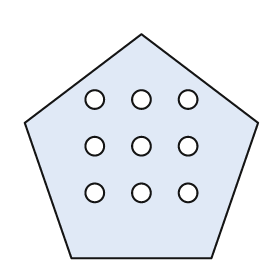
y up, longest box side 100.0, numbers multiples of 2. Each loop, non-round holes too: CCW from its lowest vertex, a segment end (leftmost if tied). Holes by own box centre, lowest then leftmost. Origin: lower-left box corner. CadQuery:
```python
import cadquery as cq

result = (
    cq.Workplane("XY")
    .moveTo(20.0, 0.0)
    .lineTo(80.0, 0.0)
    .lineTo(100.0, 58.0)
    .lineTo(50.0, 96.0)
    .lineTo(0.0, 58.0)
    .close()
    .moveTo(30.0, 28.0)
    .circle(4.0)
    .moveTo(50.0, 28.0)
    .circle(4.0)
    .moveTo(70.0, 28.0)
    .circle(4.0)
    .moveTo(30.0, 48.0)
    .circle(4.0)
    .moveTo(50.0, 48.0)
    .circle(4.0)
    .moveTo(70.0, 48.0)
    .circle(4.0)
    .moveTo(30.0, 68.0)
    .circle(4.0)
    .moveTo(50.0, 68.0)
    .circle(4.0)
    .moveTo(70.0, 68.0)
    .circle(4.0)
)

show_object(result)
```